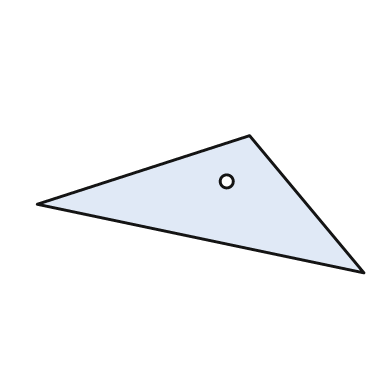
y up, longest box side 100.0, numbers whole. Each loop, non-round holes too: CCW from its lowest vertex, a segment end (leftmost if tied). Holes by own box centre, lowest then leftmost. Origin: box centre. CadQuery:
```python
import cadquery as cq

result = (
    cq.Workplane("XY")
    .moveTo(50.0, -21.0)
    .lineTo(15.0, 21.0)
    .lineTo(-50.0, 0.0)
    .close()
    .moveTo(8.0, 7.0)
    .circle(2.0)
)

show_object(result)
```